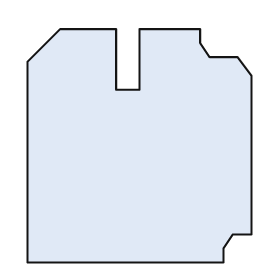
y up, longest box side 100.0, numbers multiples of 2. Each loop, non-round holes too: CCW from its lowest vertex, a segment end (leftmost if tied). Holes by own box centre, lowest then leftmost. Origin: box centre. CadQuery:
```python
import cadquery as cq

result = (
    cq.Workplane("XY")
    .moveTo(-48.0, -50.0)
    .lineTo(36.0, -50.0)
    .lineTo(36.0, -44.0)
    .lineTo(40.0, -38.0)
    .lineTo(48.0, -38.0)
    .lineTo(48.0, 30.0)
    .lineTo(42.0, 38.0)
    .lineTo(30.0, 38.0)
    .lineTo(26.0, 44.0)
    .lineTo(26.0, 50.0)
    .lineTo(0.0, 50.0)
    .lineTo(0.0, 24.0)
    .lineTo(-10.0, 24.0)
    .lineTo(-10.0, 50.0)
    .lineTo(-34.0, 50.0)
    .lineTo(-48.0, 36.0)
    .close()
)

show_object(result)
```